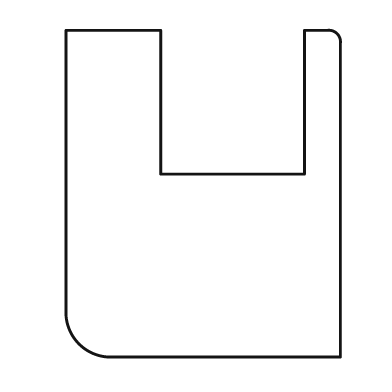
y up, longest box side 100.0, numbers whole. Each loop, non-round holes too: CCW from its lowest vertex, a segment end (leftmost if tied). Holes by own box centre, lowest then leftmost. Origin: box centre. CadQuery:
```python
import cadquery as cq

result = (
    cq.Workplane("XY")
    .moveTo(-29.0, -50.0)
    .lineTo(42.0, -50.0)
    .lineTo(42.0, 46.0)
    .threePointArc((41.0, 49.0), (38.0, 50.0))
    .lineTo(31.0, 50.0)
    .lineTo(31.0, 6.0)
    .lineTo(-13.0, 6.0)
    .lineTo(-13.0, 50.0)
    .lineTo(-42.0, 50.0)
    .lineTo(-42.0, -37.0)
    .threePointArc((-38.0, -46.0), (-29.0, -50.0))
    .close()
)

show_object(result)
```